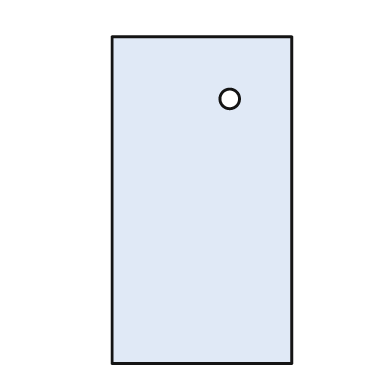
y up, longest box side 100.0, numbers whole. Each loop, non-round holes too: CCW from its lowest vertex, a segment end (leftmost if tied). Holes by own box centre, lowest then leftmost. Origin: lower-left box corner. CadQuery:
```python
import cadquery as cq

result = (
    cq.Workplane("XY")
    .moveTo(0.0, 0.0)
    .lineTo(55.0, 0.0)
    .lineTo(55.0, 100.0)
    .lineTo(0.0, 100.0)
    .close()
    .moveTo(36.0, 81.0)
    .circle(3.0)
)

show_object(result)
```